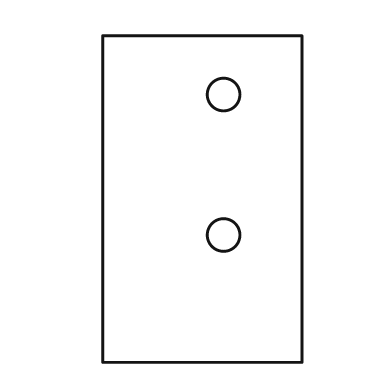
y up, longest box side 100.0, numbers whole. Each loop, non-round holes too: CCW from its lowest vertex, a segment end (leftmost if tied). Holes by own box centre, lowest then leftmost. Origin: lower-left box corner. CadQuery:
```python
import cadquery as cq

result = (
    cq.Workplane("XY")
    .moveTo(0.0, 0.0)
    .lineTo(61.0, 0.0)
    .lineTo(61.0, 100.0)
    .lineTo(0.0, 100.0)
    .close()
    .moveTo(37.0, 39.0)
    .circle(5.0)
    .moveTo(37.0, 82.0)
    .circle(5.0)
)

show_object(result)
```